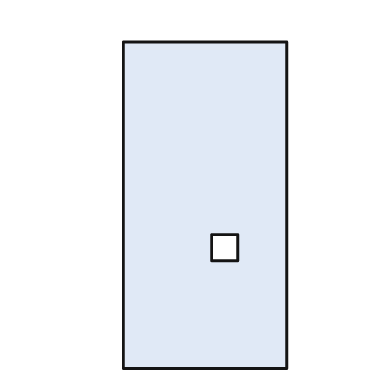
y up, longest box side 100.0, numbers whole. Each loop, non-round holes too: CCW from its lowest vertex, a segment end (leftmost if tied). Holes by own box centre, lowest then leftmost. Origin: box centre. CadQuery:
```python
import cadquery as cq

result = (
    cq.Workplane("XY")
    .moveTo(-25.0, -50.0)
    .lineTo(25.0, -50.0)
    .lineTo(25.0, 50.0)
    .lineTo(-25.0, 50.0)
    .close()
    .moveTo(2.0, -17.0)
    .lineTo(10.0, -17.0)
    .lineTo(10.0, -9.0)
    .lineTo(2.0, -9.0)
    .close()
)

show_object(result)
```